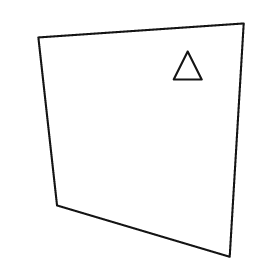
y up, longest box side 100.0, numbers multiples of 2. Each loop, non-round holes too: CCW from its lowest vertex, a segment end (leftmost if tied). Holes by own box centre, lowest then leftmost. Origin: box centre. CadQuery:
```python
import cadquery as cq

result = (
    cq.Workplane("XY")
    .moveTo(38.0, -50.0)
    .lineTo(44.0, 50.0)
    .lineTo(-44.0, 44.0)
    .lineTo(-36.0, -28.0)
    .close()
    .moveTo(14.0, 26.0)
    .lineTo(26.0, 26.0)
    .lineTo(20.0, 38.0)
    .close()
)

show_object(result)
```